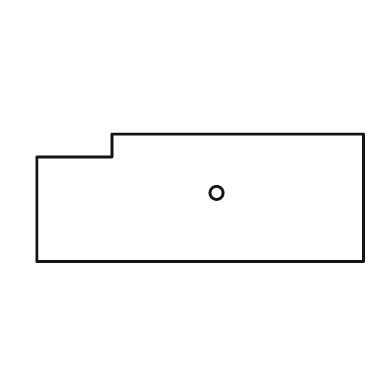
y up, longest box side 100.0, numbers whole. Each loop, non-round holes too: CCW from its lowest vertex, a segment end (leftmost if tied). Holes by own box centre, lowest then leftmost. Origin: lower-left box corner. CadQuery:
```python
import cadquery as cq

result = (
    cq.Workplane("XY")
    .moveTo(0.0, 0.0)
    .lineTo(100.0, 0.0)
    .lineTo(100.0, 39.0)
    .lineTo(23.0, 39.0)
    .lineTo(23.0, 32.0)
    .lineTo(0.0, 32.0)
    .close()
    .moveTo(55.0, 21.0)
    .circle(2.0)
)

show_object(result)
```